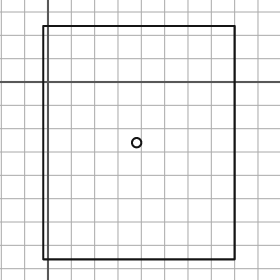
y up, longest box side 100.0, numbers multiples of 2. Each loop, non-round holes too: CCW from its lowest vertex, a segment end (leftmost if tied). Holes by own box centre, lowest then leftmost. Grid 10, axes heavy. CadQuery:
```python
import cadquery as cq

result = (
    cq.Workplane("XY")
    .moveTo(-2.0, -76.0)
    .lineTo(80.0, -76.0)
    .lineTo(80.0, 24.0)
    .lineTo(-2.0, 24.0)
    .close()
    .moveTo(38.0, -26.0)
    .circle(2.0)
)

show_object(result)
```